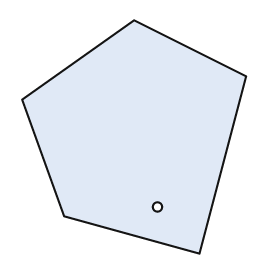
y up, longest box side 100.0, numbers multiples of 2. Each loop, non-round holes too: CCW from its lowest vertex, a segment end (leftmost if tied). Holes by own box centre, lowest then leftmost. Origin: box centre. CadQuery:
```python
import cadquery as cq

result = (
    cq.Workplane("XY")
    .moveTo(28.0, -50.0)
    .lineTo(48.0, 26.0)
    .lineTo(0.0, 50.0)
    .lineTo(-48.0, 16.0)
    .lineTo(-30.0, -34.0)
    .close()
    .moveTo(10.0, -30.0)
    .circle(2.0)
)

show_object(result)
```